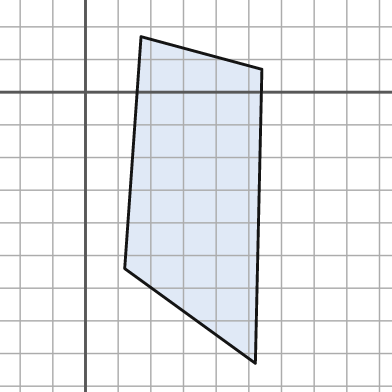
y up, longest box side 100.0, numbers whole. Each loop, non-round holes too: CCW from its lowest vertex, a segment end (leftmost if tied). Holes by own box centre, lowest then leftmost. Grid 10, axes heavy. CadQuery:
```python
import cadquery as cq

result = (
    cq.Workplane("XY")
    .moveTo(52.0, -83.0)
    .lineTo(54.0, 7.0)
    .lineTo(17.0, 17.0)
    .lineTo(12.0, -54.0)
    .close()
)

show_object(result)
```